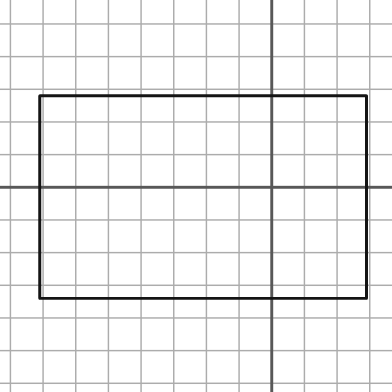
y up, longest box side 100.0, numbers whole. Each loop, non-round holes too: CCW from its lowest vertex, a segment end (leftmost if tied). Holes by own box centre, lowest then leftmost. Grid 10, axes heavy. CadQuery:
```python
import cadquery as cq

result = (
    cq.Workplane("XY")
    .moveTo(-71.0, -34.0)
    .lineTo(29.0, -34.0)
    .lineTo(29.0, 28.0)
    .lineTo(-71.0, 28.0)
    .close()
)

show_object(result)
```